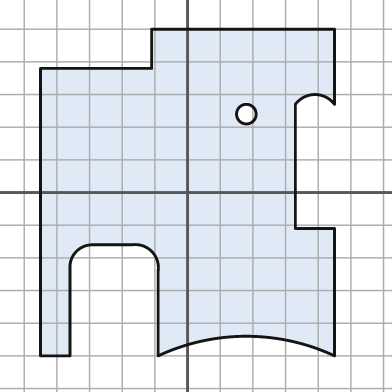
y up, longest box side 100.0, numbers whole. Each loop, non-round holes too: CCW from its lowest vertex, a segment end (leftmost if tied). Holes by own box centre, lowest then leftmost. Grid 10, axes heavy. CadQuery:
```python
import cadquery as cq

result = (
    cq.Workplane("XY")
    .moveTo(-45.0, -50.0)
    .lineTo(-36.0, -50.0)
    .lineTo(-36.0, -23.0)
    .threePointArc((-34.0, -18.0), (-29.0, -16.0))
    .lineTo(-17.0, -16.0)
    .threePointArc((-11.0, -18.0), (-9.0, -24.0))
    .lineTo(-9.0, -50.0)
    .threePointArc((18.0, -44.0), (45.0, -50.0))
    .lineTo(45.0, -11.0)
    .lineTo(33.0, -11.0)
    .lineTo(33.0, 27.0)
    .threePointArc((39.0, 30.0), (45.0, 27.0))
    .lineTo(45.0, 50.0)
    .lineTo(-11.0, 50.0)
    .lineTo(-11.0, 38.0)
    .lineTo(-45.0, 38.0)
    .close()
    .moveTo(18.0, 24.0)
    .circle(3.0)
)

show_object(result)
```